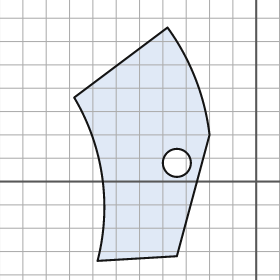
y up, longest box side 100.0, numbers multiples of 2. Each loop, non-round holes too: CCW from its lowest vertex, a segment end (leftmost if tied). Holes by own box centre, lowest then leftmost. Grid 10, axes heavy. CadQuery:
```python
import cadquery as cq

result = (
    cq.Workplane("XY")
    .moveTo(-68.0, -34.0)
    .lineTo(-34.0, -32.0)
    .lineTo(-20.0, 20.0)
    .threePointArc((-26.0, 44.0), (-38.0, 66.0))
    .lineTo(-78.0, 36.0)
    .threePointArc((-66.0, 2.0), (-68.0, -34.0))
    .close()
    .moveTo(-34.0, 8.0)
    .circle(6.0)
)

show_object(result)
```